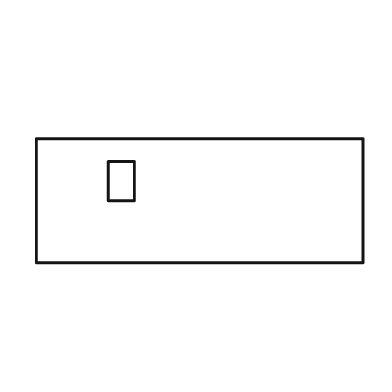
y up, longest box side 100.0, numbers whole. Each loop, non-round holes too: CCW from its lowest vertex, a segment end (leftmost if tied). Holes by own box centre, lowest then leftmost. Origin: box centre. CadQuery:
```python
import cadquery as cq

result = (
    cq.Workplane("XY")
    .moveTo(-50.0, -19.0)
    .lineTo(50.0, -19.0)
    .lineTo(50.0, 19.0)
    .lineTo(-50.0, 19.0)
    .close()
    .moveTo(-28.0, 0.0)
    .lineTo(-20.0, 0.0)
    .lineTo(-20.0, 12.0)
    .lineTo(-28.0, 12.0)
    .close()
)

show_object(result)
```